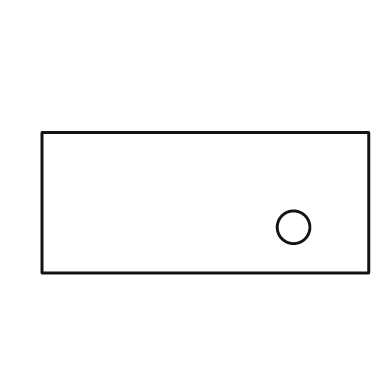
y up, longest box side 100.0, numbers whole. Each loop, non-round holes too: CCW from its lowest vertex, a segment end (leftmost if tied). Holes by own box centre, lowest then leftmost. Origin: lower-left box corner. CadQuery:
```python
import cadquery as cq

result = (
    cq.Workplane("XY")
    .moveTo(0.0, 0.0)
    .lineTo(100.0, 0.0)
    .lineTo(100.0, 43.0)
    .lineTo(0.0, 43.0)
    .close()
    .moveTo(77.0, 14.0)
    .circle(5.0)
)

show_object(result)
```